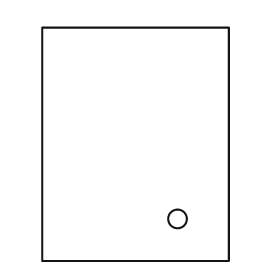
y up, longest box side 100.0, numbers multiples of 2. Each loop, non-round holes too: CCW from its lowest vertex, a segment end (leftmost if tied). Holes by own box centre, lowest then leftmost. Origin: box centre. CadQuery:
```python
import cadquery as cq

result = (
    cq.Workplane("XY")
    .moveTo(-40.0, -50.0)
    .lineTo(40.0, -50.0)
    .lineTo(40.0, 50.0)
    .lineTo(-40.0, 50.0)
    .close()
    .moveTo(18.0, -32.0)
    .circle(4.0)
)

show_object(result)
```